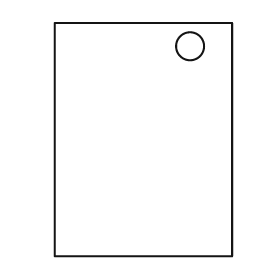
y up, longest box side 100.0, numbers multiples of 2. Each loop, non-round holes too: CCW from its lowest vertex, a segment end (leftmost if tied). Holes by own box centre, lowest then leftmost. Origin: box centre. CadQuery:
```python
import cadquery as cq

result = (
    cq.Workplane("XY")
    .moveTo(-38.0, -50.0)
    .lineTo(38.0, -50.0)
    .lineTo(38.0, 50.0)
    .lineTo(-38.0, 50.0)
    .close()
    .moveTo(20.0, 40.0)
    .circle(6.0)
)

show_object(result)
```